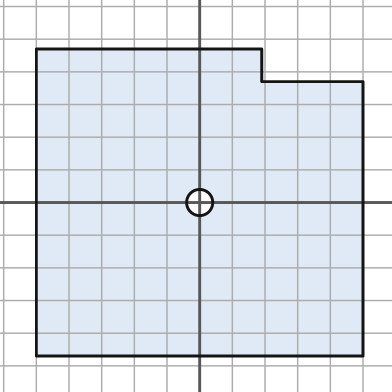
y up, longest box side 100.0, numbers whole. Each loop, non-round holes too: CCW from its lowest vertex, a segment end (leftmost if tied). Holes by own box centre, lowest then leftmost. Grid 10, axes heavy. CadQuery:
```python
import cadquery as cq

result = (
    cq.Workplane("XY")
    .moveTo(-50.0, -47.0)
    .lineTo(50.0, -47.0)
    .lineTo(50.0, 37.0)
    .lineTo(19.0, 37.0)
    .lineTo(19.0, 47.0)
    .lineTo(-50.0, 47.0)
    .close()
    .moveTo(0.0, 0.0)
    .circle(4.0)
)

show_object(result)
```